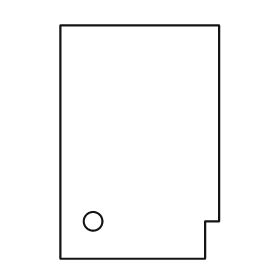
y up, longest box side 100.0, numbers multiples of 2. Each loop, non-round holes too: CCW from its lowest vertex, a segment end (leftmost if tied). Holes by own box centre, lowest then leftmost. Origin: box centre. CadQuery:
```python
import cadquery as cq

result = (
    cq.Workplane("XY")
    .moveTo(-34.0, -50.0)
    .lineTo(28.0, -50.0)
    .lineTo(28.0, -34.0)
    .lineTo(34.0, -34.0)
    .lineTo(34.0, 50.0)
    .lineTo(-34.0, 50.0)
    .close()
    .moveTo(-20.0, -34.0)
    .circle(4.0)
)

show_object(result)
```